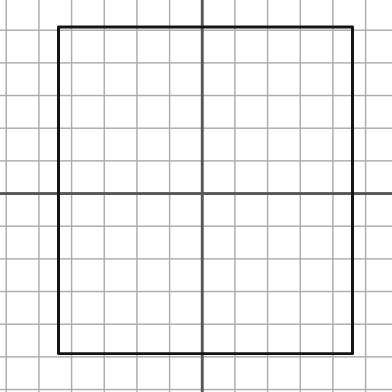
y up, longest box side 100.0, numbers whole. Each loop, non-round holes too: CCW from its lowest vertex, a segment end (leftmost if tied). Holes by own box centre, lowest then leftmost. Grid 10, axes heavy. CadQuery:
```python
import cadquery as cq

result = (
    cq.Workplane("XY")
    .moveTo(-44.0, -49.0)
    .lineTo(46.0, -49.0)
    .lineTo(46.0, 51.0)
    .lineTo(-44.0, 51.0)
    .close()
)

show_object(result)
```